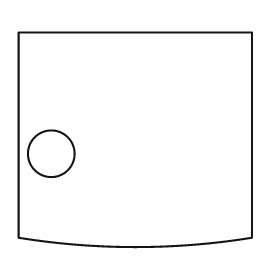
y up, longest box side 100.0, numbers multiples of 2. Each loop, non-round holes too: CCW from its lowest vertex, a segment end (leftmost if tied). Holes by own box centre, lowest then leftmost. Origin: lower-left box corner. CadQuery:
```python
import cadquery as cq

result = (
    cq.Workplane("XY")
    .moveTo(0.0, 4.0)
    .threePointArc((50.0, 0.0), (100.0, 4.0))
    .lineTo(100.0, 92.0)
    .lineTo(0.0, 92.0)
    .close()
    .moveTo(14.0, 40.0)
    .circle(10.0)
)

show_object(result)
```